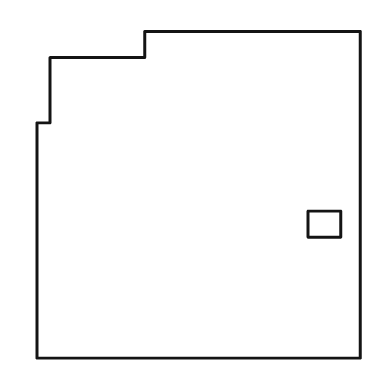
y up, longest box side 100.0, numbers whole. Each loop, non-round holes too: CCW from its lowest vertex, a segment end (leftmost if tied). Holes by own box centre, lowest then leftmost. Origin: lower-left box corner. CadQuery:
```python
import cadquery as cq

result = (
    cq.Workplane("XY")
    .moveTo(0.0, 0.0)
    .lineTo(99.0, 0.0)
    .lineTo(99.0, 100.0)
    .lineTo(33.0, 100.0)
    .lineTo(33.0, 92.0)
    .lineTo(4.0, 92.0)
    .lineTo(4.0, 72.0)
    .lineTo(0.0, 72.0)
    .close()
    .moveTo(83.0, 37.0)
    .lineTo(93.0, 37.0)
    .lineTo(93.0, 45.0)
    .lineTo(83.0, 45.0)
    .close()
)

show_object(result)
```